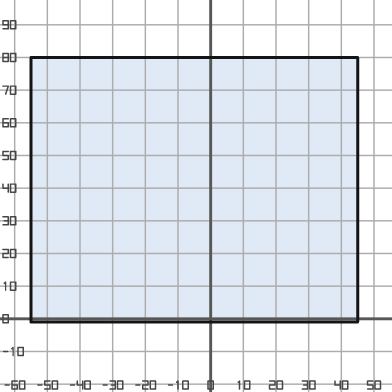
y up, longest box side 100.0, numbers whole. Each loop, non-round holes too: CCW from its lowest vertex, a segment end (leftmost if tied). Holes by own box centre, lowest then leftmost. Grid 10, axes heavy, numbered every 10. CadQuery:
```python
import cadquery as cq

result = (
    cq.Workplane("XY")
    .moveTo(-55.0, -1.0)
    .lineTo(45.0, -1.0)
    .lineTo(45.0, 80.0)
    .lineTo(-55.0, 80.0)
    .close()
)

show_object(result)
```